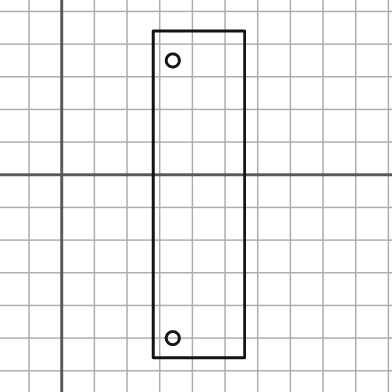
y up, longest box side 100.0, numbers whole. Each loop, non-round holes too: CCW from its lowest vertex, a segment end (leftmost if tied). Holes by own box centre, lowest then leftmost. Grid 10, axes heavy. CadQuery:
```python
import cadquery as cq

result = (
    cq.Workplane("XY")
    .moveTo(28.0, -56.0)
    .lineTo(56.0, -56.0)
    .lineTo(56.0, 44.0)
    .lineTo(28.0, 44.0)
    .close()
    .moveTo(34.0, -50.0)
    .circle(2.0)
    .moveTo(34.0, 35.0)
    .circle(2.0)
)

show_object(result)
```